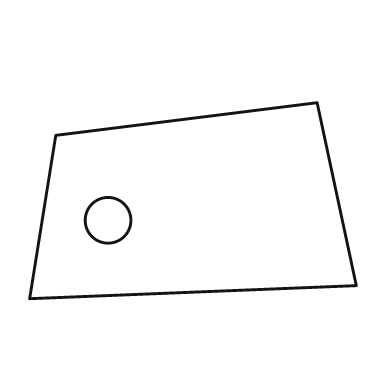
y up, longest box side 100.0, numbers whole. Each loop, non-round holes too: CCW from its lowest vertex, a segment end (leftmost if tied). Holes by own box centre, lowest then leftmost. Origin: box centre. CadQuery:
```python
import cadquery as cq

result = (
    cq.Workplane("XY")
    .moveTo(-50.0, -30.0)
    .lineTo(50.0, -26.0)
    .lineTo(38.0, 30.0)
    .lineTo(-42.0, 20.0)
    .close()
    .moveTo(-26.0, -6.0)
    .circle(7.0)
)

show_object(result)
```